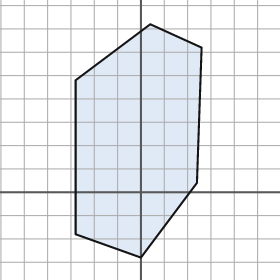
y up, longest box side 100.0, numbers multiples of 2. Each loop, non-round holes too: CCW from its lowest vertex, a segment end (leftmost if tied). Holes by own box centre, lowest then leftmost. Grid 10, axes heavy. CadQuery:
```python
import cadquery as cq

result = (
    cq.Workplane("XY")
    .moveTo(0.0, -28.0)
    .lineTo(24.0, 4.0)
    .lineTo(26.0, 62.0)
    .lineTo(4.0, 72.0)
    .lineTo(-28.0, 48.0)
    .lineTo(-28.0, -18.0)
    .close()
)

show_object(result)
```